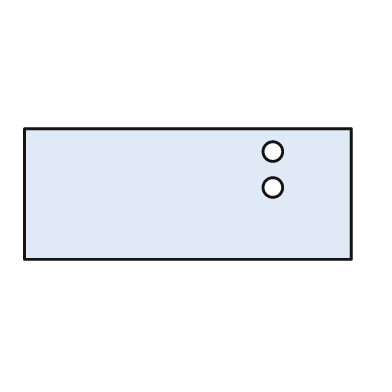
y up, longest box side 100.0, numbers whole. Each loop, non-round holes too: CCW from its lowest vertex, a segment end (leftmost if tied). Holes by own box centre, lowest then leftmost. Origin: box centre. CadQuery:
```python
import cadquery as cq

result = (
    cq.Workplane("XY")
    .moveTo(-50.0, -20.0)
    .lineTo(50.0, -20.0)
    .lineTo(50.0, 20.0)
    .lineTo(-50.0, 20.0)
    .close()
    .moveTo(26.0, 2.0)
    .circle(3.0)
    .moveTo(26.0, 13.0)
    .circle(3.0)
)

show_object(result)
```